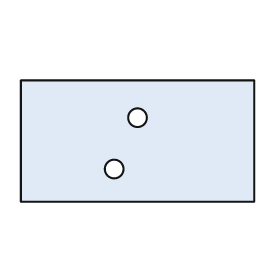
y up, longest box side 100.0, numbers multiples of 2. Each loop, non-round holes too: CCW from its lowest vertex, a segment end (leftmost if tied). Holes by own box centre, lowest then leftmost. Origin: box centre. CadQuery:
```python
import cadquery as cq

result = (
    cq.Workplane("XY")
    .moveTo(-50.0, -26.0)
    .lineTo(50.0, -26.0)
    .lineTo(50.0, 26.0)
    .lineTo(-50.0, 26.0)
    .close()
    .moveTo(-10.0, -12.0)
    .circle(4.0)
    .moveTo(0.0, 10.0)
    .circle(4.0)
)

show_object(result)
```